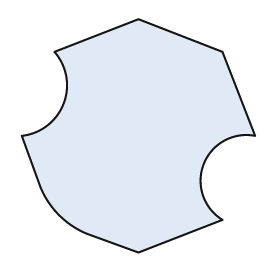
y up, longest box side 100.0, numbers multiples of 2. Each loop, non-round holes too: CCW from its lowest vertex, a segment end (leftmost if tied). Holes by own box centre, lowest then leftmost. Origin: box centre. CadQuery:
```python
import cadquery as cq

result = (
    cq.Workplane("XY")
    .moveTo(0.0, -50.0)
    .lineTo(36.0, -36.0)
    .threePointArc((28.0, -12.0), (50.0, 0.0))
    .lineTo(36.0, 36.0)
    .lineTo(0.0, 50.0)
    .lineTo(-36.0, 36.0)
    .threePointArc((-32.0, 14.0), (-50.0, 0.0))
    .lineTo(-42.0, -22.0)
    .threePointArc((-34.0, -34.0), (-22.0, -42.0))
    .close()
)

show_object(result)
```